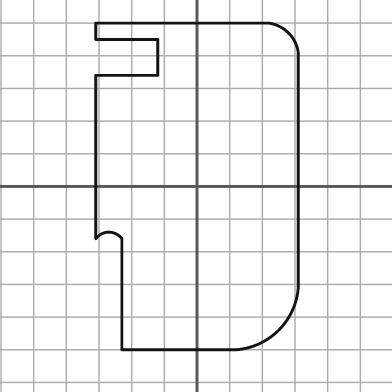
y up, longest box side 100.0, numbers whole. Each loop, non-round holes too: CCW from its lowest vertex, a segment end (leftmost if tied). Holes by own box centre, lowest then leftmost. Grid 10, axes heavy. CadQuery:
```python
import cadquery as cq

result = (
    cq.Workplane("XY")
    .moveTo(-23.0, -50.0)
    .lineTo(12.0, -50.0)
    .threePointArc((25.0, -44.0), (31.0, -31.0))
    .lineTo(31.0, 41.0)
    .threePointArc((28.0, 47.0), (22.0, 50.0))
    .lineTo(-31.0, 50.0)
    .lineTo(-31.0, 45.0)
    .lineTo(-12.0, 45.0)
    .lineTo(-12.0, 34.0)
    .lineTo(-31.0, 34.0)
    .lineTo(-31.0, -16.0)
    .threePointArc((-27.0, -14.0), (-23.0, -16.0))
    .close()
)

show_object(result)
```